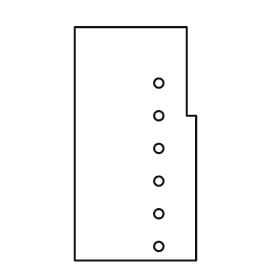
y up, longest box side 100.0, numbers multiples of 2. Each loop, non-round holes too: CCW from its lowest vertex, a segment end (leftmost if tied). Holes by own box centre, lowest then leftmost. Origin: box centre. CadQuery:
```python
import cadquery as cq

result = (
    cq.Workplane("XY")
    .moveTo(-26.0, -50.0)
    .lineTo(26.0, -50.0)
    .lineTo(26.0, 12.0)
    .lineTo(22.0, 12.0)
    .lineTo(22.0, 50.0)
    .lineTo(-26.0, 50.0)
    .close()
    .moveTo(10.0, -44.0)
    .circle(2.0)
    .moveTo(10.0, -30.0)
    .circle(2.0)
    .moveTo(10.0, -16.0)
    .circle(2.0)
    .moveTo(10.0, -2.0)
    .circle(2.0)
    .moveTo(10.0, 12.0)
    .circle(2.0)
    .moveTo(10.0, 26.0)
    .circle(2.0)
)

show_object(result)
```